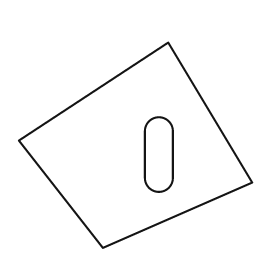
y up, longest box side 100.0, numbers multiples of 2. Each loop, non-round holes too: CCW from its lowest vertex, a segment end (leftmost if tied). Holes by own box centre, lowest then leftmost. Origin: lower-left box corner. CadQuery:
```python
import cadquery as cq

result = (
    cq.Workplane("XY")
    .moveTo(36.0, 0.0)
    .lineTo(100.0, 28.0)
    .lineTo(64.0, 88.0)
    .lineTo(0.0, 46.0)
    .close()
    .moveTo(54.0, 30.0)
    .threePointArc((60.0, 24.0), (66.0, 30.0))
    .lineTo(66.0, 50.0)
    .threePointArc((60.0, 56.0), (54.0, 50.0))
    .close()
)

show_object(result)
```